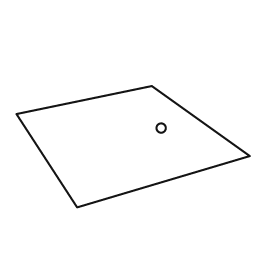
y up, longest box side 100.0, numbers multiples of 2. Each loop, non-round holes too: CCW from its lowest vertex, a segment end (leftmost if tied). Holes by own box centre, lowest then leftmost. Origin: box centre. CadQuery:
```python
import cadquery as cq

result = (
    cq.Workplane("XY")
    .moveTo(-24.0, -26.0)
    .lineTo(50.0, -4.0)
    .lineTo(8.0, 26.0)
    .lineTo(-50.0, 14.0)
    .close()
    .moveTo(12.0, 8.0)
    .circle(2.0)
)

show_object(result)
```